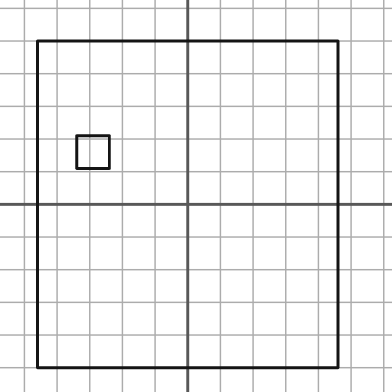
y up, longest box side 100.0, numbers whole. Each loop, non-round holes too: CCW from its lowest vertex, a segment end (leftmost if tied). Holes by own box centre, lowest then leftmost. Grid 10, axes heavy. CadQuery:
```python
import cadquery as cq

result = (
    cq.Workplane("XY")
    .moveTo(-46.0, -50.0)
    .lineTo(46.0, -50.0)
    .lineTo(46.0, 50.0)
    .lineTo(-46.0, 50.0)
    .close()
    .moveTo(-34.0, 11.0)
    .lineTo(-24.0, 11.0)
    .lineTo(-24.0, 21.0)
    .lineTo(-34.0, 21.0)
    .close()
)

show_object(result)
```